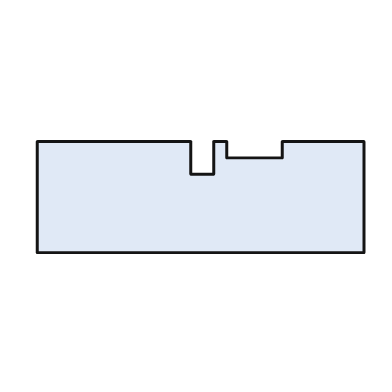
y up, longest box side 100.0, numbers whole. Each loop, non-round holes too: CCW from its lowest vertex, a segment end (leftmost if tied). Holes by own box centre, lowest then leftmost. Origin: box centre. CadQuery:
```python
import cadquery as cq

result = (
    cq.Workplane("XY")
    .moveTo(-50.0, -17.0)
    .lineTo(50.0, -17.0)
    .lineTo(50.0, 17.0)
    .lineTo(25.0, 17.0)
    .lineTo(25.0, 12.0)
    .lineTo(8.0, 12.0)
    .lineTo(8.0, 17.0)
    .lineTo(4.0, 17.0)
    .lineTo(4.0, 7.0)
    .lineTo(-3.0, 7.0)
    .lineTo(-3.0, 17.0)
    .lineTo(-50.0, 17.0)
    .close()
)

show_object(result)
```